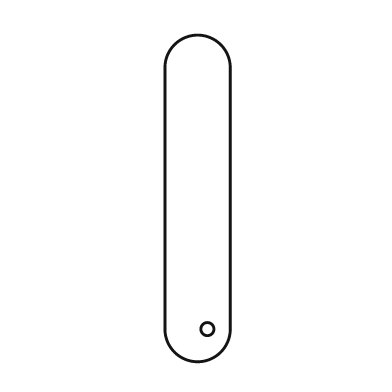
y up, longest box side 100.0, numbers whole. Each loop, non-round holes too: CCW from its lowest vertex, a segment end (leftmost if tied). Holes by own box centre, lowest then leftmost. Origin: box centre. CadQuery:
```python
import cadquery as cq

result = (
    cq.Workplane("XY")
    .moveTo(-10.0, -40.0)
    .threePointArc((0.0, -50.0), (10.0, -40.0))
    .lineTo(10.0, 40.0)
    .threePointArc((0.0, 50.0), (-10.0, 40.0))
    .close()
    .moveTo(3.0, -40.0)
    .circle(2.0)
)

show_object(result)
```